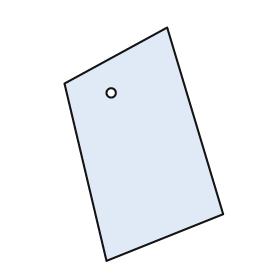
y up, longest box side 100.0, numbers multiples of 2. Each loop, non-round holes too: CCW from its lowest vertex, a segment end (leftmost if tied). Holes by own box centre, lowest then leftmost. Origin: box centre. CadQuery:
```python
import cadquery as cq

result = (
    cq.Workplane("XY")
    .moveTo(-16.0, -50.0)
    .lineTo(34.0, -30.0)
    .lineTo(10.0, 50.0)
    .lineTo(-34.0, 26.0)
    .close()
    .moveTo(-14.0, 22.0)
    .circle(2.0)
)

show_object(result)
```